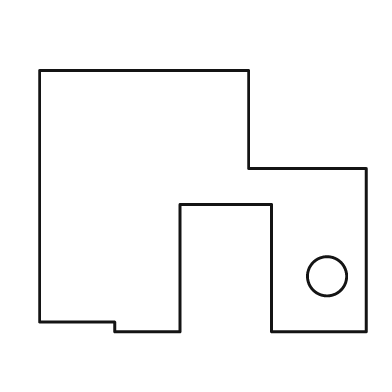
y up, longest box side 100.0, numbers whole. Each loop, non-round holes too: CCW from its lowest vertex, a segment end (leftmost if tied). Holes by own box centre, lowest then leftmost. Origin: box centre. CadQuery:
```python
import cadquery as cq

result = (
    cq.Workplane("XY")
    .moveTo(-27.0, -40.0)
    .lineTo(-7.0, -40.0)
    .lineTo(-7.0, -1.0)
    .lineTo(21.0, -1.0)
    .lineTo(21.0, -40.0)
    .lineTo(50.0, -40.0)
    .lineTo(50.0, 10.0)
    .lineTo(14.0, 10.0)
    .lineTo(14.0, 40.0)
    .lineTo(-50.0, 40.0)
    .lineTo(-50.0, -37.0)
    .lineTo(-27.0, -37.0)
    .close()
    .moveTo(38.0, -23.0)
    .circle(6.0)
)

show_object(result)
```